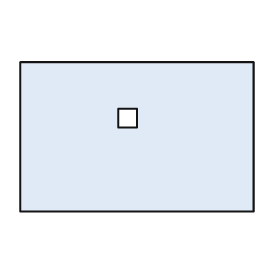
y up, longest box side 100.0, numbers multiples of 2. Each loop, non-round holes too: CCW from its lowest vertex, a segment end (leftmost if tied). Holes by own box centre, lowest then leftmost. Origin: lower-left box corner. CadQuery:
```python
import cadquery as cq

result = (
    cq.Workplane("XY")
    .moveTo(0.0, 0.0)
    .lineTo(100.0, 0.0)
    .lineTo(100.0, 64.0)
    .lineTo(0.0, 64.0)
    .close()
    .moveTo(42.0, 36.0)
    .lineTo(50.0, 36.0)
    .lineTo(50.0, 44.0)
    .lineTo(42.0, 44.0)
    .close()
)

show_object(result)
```